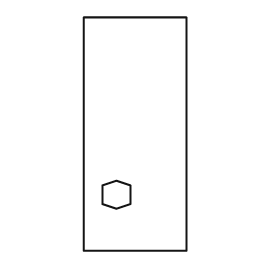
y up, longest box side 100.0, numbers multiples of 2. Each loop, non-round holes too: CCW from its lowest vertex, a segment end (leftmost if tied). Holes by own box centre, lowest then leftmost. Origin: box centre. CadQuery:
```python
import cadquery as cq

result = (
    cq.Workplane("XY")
    .moveTo(-22.0, -50.0)
    .lineTo(22.0, -50.0)
    .lineTo(22.0, 50.0)
    .lineTo(-22.0, 50.0)
    .close()
    .moveTo(-8.0, -32.0)
    .lineTo(-2.0, -30.0)
    .lineTo(-2.0, -22.0)
    .lineTo(-8.0, -20.0)
    .lineTo(-14.0, -22.0)
    .lineTo(-14.0, -30.0)
    .close()
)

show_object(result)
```